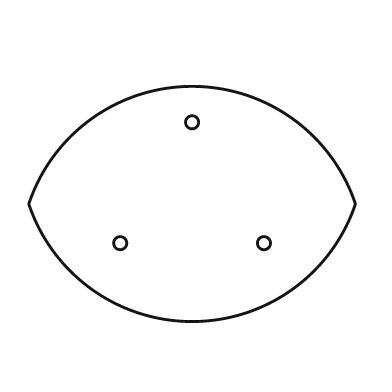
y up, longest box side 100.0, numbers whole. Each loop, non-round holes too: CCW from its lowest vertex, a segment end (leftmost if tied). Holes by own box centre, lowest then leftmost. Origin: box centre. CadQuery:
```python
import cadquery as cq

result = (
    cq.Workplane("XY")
    .moveTo(-50.0, 0.0)
    .threePointArc((0.0, -36.0), (50.0, 0.0))
    .threePointArc((0.0, 36.0), (-50.0, 0.0))
    .close()
    .moveTo(-22.0, -12.0)
    .circle(2.0)
    .moveTo(22.0, -12.0)
    .circle(2.0)
    .moveTo(0.0, 25.0)
    .circle(2.0)
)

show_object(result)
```